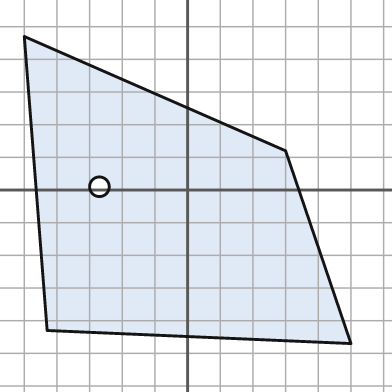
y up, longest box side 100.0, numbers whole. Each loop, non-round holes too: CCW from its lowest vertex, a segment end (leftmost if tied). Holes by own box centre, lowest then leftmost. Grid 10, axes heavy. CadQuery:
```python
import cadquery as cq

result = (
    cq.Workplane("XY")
    .moveTo(50.0, -47.0)
    .lineTo(30.0, 12.0)
    .lineTo(-50.0, 47.0)
    .lineTo(-43.0, -43.0)
    .close()
    .moveTo(-27.0, 1.0)
    .circle(3.0)
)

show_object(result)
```